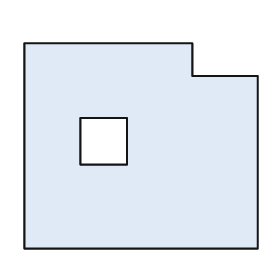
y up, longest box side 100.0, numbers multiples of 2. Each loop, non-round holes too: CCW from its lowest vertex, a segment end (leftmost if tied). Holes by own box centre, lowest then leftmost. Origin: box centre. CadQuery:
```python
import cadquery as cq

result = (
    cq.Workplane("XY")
    .moveTo(-50.0, -44.0)
    .lineTo(50.0, -44.0)
    .lineTo(50.0, 30.0)
    .lineTo(22.0, 30.0)
    .lineTo(22.0, 44.0)
    .lineTo(-50.0, 44.0)
    .close()
    .moveTo(-26.0, -8.0)
    .lineTo(-6.0, -8.0)
    .lineTo(-6.0, 12.0)
    .lineTo(-26.0, 12.0)
    .close()
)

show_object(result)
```